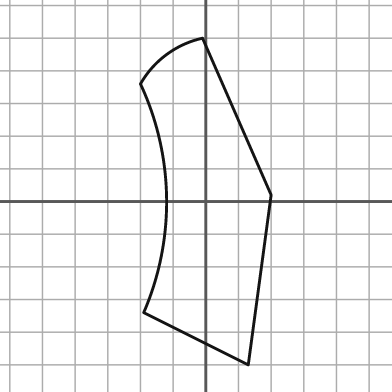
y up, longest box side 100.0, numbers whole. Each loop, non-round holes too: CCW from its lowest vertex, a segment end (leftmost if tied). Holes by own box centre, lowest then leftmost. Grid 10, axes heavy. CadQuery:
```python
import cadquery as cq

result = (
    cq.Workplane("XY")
    .moveTo(13.0, -50.0)
    .lineTo(20.0, 2.0)
    .lineTo(-1.0, 50.0)
    .threePointArc((-12.0, 45.0), (-20.0, 36.0))
    .threePointArc((-12.0, 1.0), (-19.0, -34.0))
    .close()
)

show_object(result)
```